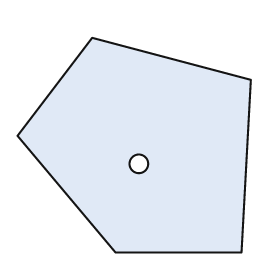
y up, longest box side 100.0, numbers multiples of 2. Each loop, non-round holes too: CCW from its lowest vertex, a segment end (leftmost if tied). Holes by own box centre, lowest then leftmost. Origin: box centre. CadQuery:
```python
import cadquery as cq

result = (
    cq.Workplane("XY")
    .moveTo(-8.0, -46.0)
    .lineTo(46.0, -46.0)
    .lineTo(50.0, 28.0)
    .lineTo(-18.0, 46.0)
    .lineTo(-50.0, 4.0)
    .close()
    .moveTo(2.0, -8.0)
    .circle(4.0)
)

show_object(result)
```